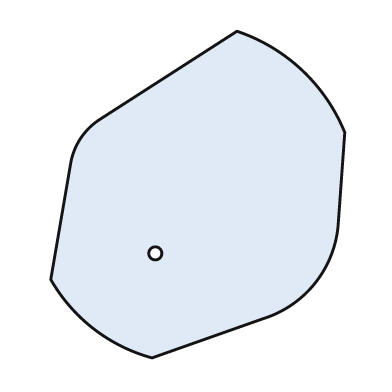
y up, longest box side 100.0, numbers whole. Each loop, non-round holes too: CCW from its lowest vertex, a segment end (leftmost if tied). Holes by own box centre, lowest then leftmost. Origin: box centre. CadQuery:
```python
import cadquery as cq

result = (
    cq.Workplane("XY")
    .moveTo(-14.0, -50.0)
    .lineTo(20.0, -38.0)
    .threePointArc((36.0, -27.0), (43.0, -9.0))
    .lineTo(45.0, 19.0)
    .threePointArc((32.0, 38.0), (12.0, 50.0))
    .lineTo(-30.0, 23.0)
    .threePointArc((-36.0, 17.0), (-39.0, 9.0))
    .lineTo(-45.0, -26.0)
    .threePointArc((-32.0, -41.0), (-14.0, -50.0))
    .close()
    .moveTo(-13.0, -18.0)
    .circle(2.0)
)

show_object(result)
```